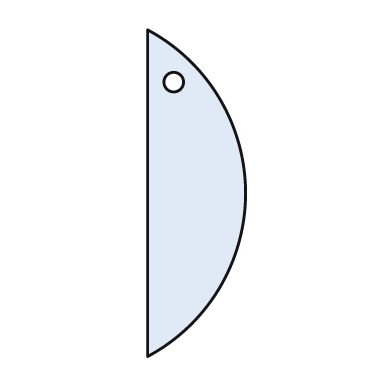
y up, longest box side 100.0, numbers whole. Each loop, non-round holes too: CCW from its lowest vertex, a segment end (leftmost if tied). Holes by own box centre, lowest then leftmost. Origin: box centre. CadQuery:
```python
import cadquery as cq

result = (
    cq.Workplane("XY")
    .moveTo(-15.0, -50.0)
    .threePointArc((15.0, 0.0), (-15.0, 50.0))
    .close()
    .moveTo(-7.0, 34.0)
    .circle(3.0)
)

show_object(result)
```